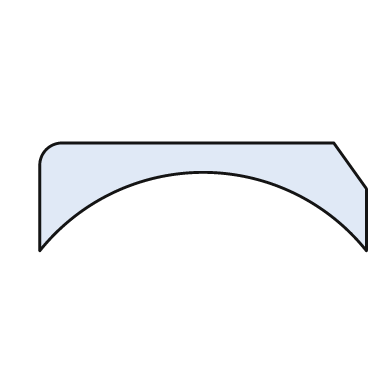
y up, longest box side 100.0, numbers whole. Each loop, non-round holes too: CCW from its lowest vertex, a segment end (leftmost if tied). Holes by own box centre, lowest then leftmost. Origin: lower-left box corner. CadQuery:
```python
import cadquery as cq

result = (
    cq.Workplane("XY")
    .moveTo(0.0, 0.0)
    .threePointArc((50.0, 24.0), (100.0, 0.0))
    .lineTo(100.0, 19.0)
    .lineTo(90.0, 33.0)
    .lineTo(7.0, 33.0)
    .threePointArc((2.0, 31.0), (0.0, 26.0))
    .close()
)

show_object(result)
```